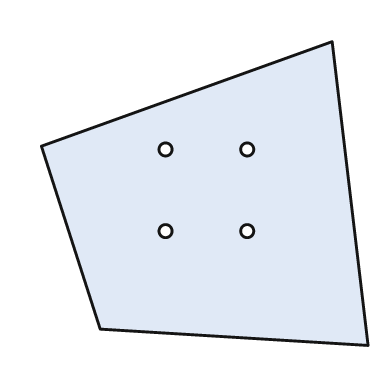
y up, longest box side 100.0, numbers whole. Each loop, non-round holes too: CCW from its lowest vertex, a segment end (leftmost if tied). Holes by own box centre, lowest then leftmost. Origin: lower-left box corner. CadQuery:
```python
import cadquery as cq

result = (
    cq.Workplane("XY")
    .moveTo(100.0, 0.0)
    .lineTo(89.0, 93.0)
    .lineTo(0.0, 61.0)
    .lineTo(18.0, 5.0)
    .close()
    .moveTo(38.0, 35.0)
    .circle(2.0)
    .moveTo(63.0, 35.0)
    .circle(2.0)
    .moveTo(38.0, 60.0)
    .circle(2.0)
    .moveTo(63.0, 60.0)
    .circle(2.0)
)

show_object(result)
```